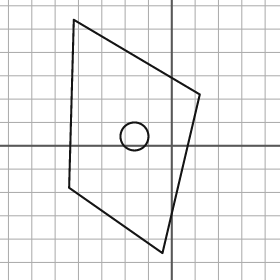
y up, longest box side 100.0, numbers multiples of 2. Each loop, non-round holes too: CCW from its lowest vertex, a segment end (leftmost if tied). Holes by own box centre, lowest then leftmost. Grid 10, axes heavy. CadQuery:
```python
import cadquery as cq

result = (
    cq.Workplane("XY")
    .moveTo(-4.0, -46.0)
    .lineTo(12.0, 22.0)
    .lineTo(-42.0, 54.0)
    .lineTo(-44.0, -18.0)
    .close()
    .moveTo(-16.0, 4.0)
    .circle(6.0)
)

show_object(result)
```